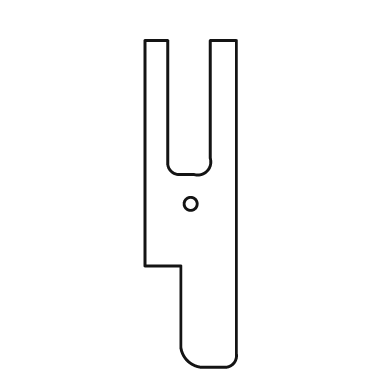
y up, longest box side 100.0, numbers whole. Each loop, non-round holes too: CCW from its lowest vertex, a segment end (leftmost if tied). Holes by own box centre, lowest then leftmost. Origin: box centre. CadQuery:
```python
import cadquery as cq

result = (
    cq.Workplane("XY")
    .moveTo(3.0, -50.0)
    .lineTo(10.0, -50.0)
    .threePointArc((13.0, -49.0), (14.0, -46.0))
    .lineTo(14.0, 50.0)
    .lineTo(6.0, 50.0)
    .lineTo(6.0, 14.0)
    .threePointArc((5.0, 10.0), (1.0, 9.0))
    .lineTo(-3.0, 9.0)
    .threePointArc((-6.0, 10.0), (-7.0, 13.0))
    .lineTo(-7.0, 50.0)
    .lineTo(-14.0, 50.0)
    .lineTo(-14.0, -19.0)
    .lineTo(-3.0, -19.0)
    .lineTo(-3.0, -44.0)
    .threePointArc((-1.0, -48.0), (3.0, -50.0))
    .close()
    .moveTo(0.0, 0.0)
    .circle(2.0)
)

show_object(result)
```